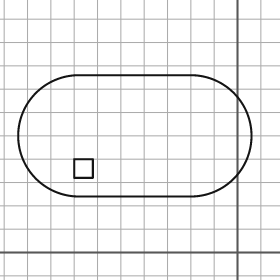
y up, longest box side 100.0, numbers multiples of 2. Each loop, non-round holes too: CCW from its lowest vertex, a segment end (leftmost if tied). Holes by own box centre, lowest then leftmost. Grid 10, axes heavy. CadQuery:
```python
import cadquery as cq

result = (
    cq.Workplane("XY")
    .moveTo(-68.0, 24.0)
    .lineTo(-20.0, 24.0)
    .threePointArc((6.0, 50.0), (-20.0, 76.0))
    .lineTo(-68.0, 76.0)
    .threePointArc((-94.0, 50.0), (-68.0, 24.0))
    .close()
    .moveTo(-70.0, 32.0)
    .lineTo(-62.0, 32.0)
    .lineTo(-62.0, 40.0)
    .lineTo(-70.0, 40.0)
    .close()
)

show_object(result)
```